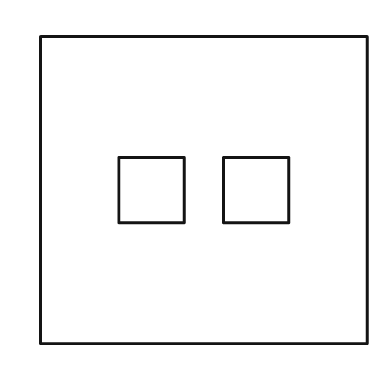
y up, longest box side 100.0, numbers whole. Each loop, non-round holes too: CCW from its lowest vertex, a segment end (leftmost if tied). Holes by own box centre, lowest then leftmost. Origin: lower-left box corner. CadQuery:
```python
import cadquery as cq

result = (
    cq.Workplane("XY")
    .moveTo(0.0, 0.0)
    .lineTo(100.0, 0.0)
    .lineTo(100.0, 94.0)
    .lineTo(0.0, 94.0)
    .close()
    .moveTo(24.0, 37.0)
    .lineTo(44.0, 37.0)
    .lineTo(44.0, 57.0)
    .lineTo(24.0, 57.0)
    .close()
    .moveTo(56.0, 37.0)
    .lineTo(76.0, 37.0)
    .lineTo(76.0, 57.0)
    .lineTo(56.0, 57.0)
    .close()
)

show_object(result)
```